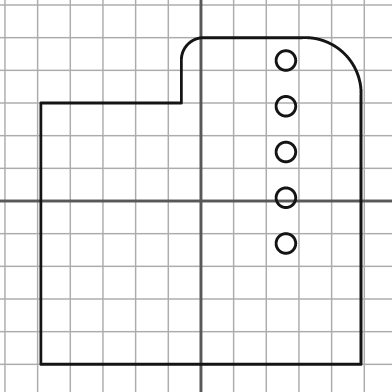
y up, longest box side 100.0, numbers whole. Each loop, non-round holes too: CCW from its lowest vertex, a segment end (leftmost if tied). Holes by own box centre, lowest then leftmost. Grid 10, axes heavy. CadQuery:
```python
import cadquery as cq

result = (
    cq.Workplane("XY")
    .moveTo(-49.0, -50.0)
    .lineTo(49.0, -50.0)
    .lineTo(49.0, 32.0)
    .threePointArc((44.0, 45.0), (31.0, 50.0))
    .lineTo(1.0, 50.0)
    .threePointArc((-4.0, 48.0), (-6.0, 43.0))
    .lineTo(-6.0, 30.0)
    .lineTo(-49.0, 30.0)
    .close()
    .moveTo(26.0, -13.0)
    .circle(3.0)
    .moveTo(26.0, 1.0)
    .circle(3.0)
    .moveTo(26.0, 15.0)
    .circle(3.0)
    .moveTo(26.0, 29.0)
    .circle(3.0)
    .moveTo(26.0, 43.0)
    .circle(3.0)
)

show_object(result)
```